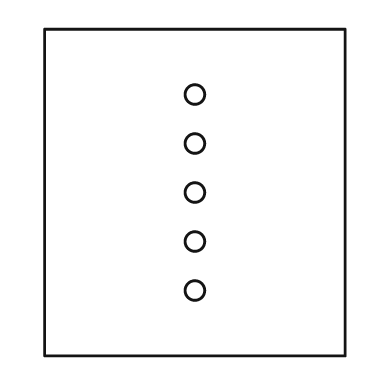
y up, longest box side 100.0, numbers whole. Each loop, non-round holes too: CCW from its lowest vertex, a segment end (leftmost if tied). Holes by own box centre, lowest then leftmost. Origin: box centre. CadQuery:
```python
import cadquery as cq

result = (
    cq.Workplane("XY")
    .moveTo(-46.0, -50.0)
    .lineTo(46.0, -50.0)
    .lineTo(46.0, 50.0)
    .lineTo(-46.0, 50.0)
    .close()
    .moveTo(0.0, -30.0)
    .circle(3.0)
    .moveTo(0.0, -15.0)
    .circle(3.0)
    .moveTo(0.0, 0.0)
    .circle(3.0)
    .moveTo(0.0, 15.0)
    .circle(3.0)
    .moveTo(0.0, 30.0)
    .circle(3.0)
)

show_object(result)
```